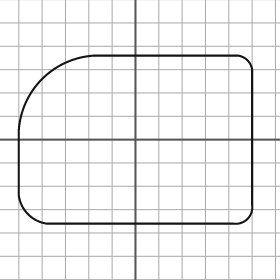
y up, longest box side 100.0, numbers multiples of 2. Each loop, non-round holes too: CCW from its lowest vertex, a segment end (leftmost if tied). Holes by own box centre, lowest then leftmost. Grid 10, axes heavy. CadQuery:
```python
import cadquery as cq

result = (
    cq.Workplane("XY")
    .moveTo(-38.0, -36.0)
    .lineTo(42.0, -36.0)
    .threePointArc((48.0, -34.0), (50.0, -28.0))
    .lineTo(50.0, 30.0)
    .threePointArc((48.0, 34.0), (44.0, 36.0))
    .lineTo(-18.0, 36.0)
    .threePointArc((-40.0, 26.0), (-50.0, 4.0))
    .lineTo(-50.0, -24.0)
    .threePointArc((-46.0, -32.0), (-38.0, -36.0))
    .close()
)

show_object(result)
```